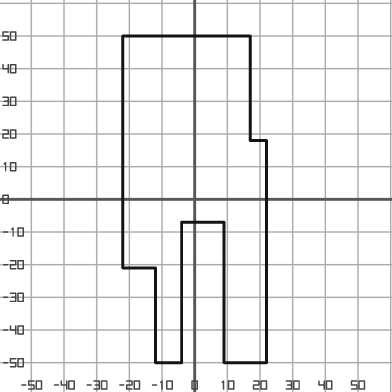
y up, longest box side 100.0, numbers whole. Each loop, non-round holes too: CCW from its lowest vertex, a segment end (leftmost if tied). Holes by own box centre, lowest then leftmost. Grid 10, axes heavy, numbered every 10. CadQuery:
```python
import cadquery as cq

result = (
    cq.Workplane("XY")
    .moveTo(-12.0, -50.0)
    .lineTo(-4.0, -50.0)
    .lineTo(-4.0, -7.0)
    .lineTo(9.0, -7.0)
    .lineTo(9.0, -50.0)
    .lineTo(22.0, -50.0)
    .lineTo(22.0, 18.0)
    .lineTo(17.0, 18.0)
    .lineTo(17.0, 50.0)
    .lineTo(-22.0, 50.0)
    .lineTo(-22.0, -21.0)
    .lineTo(-12.0, -21.0)
    .close()
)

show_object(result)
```